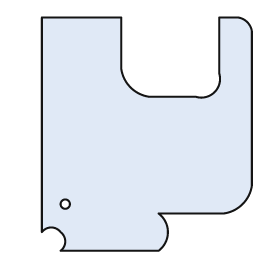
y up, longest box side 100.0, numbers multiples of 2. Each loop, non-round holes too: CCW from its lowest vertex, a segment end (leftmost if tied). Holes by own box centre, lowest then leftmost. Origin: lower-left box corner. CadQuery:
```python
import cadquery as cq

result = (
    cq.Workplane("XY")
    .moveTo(8.0, 0.0)
    .lineTo(50.0, 0.0)
    .threePointArc((54.0, 8.0), (50.0, 16.0))
    .lineTo(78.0, 16.0)
    .threePointArc((86.0, 20.0), (90.0, 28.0))
    .lineTo(90.0, 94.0)
    .threePointArc((88.0, 98.0), (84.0, 100.0))
    .lineTo(76.0, 100.0)
    .lineTo(76.0, 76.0)
    .threePointArc((74.0, 68.0), (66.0, 66.0))
    .lineTo(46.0, 66.0)
    .threePointArc((38.0, 70.0), (34.0, 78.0))
    .lineTo(34.0, 100.0)
    .lineTo(0.0, 100.0)
    .lineTo(0.0, 8.0)
    .threePointArc((4.0, 10.0), (8.0, 8.0))
    .threePointArc((10.0, 4.0), (8.0, 0.0))
    .close()
    .moveTo(10.0, 20.0)
    .circle(2.0)
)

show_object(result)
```